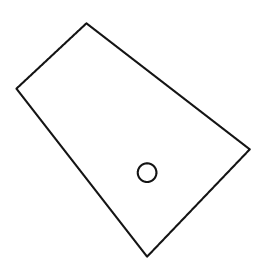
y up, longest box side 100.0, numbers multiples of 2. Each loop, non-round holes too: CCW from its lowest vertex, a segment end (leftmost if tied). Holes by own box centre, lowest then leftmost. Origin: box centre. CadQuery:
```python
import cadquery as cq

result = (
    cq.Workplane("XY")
    .moveTo(6.0, -50.0)
    .lineTo(50.0, -4.0)
    .lineTo(-20.0, 50.0)
    .lineTo(-50.0, 22.0)
    .close()
    .moveTo(6.0, -14.0)
    .circle(4.0)
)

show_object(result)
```